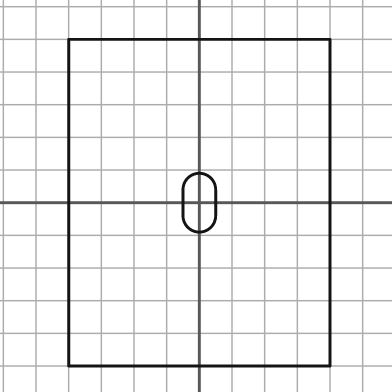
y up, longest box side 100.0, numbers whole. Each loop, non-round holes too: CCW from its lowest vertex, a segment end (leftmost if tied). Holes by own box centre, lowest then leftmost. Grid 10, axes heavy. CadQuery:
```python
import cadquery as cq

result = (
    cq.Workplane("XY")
    .moveTo(-40.0, -50.0)
    .lineTo(40.0, -50.0)
    .lineTo(40.0, 50.0)
    .lineTo(-40.0, 50.0)
    .close()
    .moveTo(-5.0, -4.0)
    .threePointArc((0.0, -9.0), (5.0, -4.0))
    .lineTo(5.0, 4.0)
    .threePointArc((0.0, 9.0), (-5.0, 4.0))
    .close()
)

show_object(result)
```